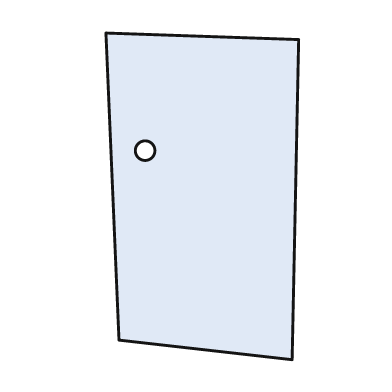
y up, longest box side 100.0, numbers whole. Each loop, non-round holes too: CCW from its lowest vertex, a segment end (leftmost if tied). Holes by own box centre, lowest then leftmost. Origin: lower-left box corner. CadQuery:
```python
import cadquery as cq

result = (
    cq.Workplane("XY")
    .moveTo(57.0, 0.0)
    .lineTo(59.0, 98.0)
    .lineTo(0.0, 100.0)
    .lineTo(4.0, 6.0)
    .close()
    .moveTo(12.0, 64.0)
    .circle(3.0)
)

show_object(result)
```